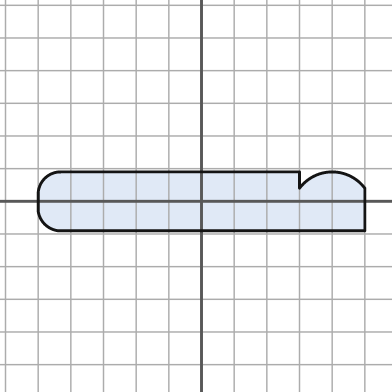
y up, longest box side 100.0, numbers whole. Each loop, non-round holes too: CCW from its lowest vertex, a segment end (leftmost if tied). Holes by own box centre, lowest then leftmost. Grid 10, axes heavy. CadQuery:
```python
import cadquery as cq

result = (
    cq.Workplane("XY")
    .moveTo(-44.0, -9.0)
    .lineTo(50.0, -9.0)
    .lineTo(50.0, 4.0)
    .threePointArc((40.0, 9.0), (30.0, 4.0))
    .lineTo(30.0, 9.0)
    .lineTo(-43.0, 9.0)
    .threePointArc((-48.0, 7.0), (-50.0, 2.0))
    .lineTo(-50.0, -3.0)
    .threePointArc((-48.0, -7.0), (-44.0, -9.0))
    .close()
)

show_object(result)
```